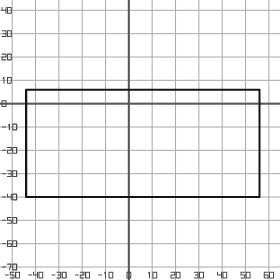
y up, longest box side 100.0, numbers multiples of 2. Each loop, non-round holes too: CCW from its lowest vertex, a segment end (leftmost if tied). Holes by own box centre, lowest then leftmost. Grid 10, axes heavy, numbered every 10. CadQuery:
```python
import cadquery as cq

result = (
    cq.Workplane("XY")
    .moveTo(-44.0, -40.0)
    .lineTo(56.0, -40.0)
    .lineTo(56.0, 6.0)
    .lineTo(-44.0, 6.0)
    .close()
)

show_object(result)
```